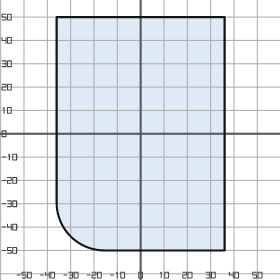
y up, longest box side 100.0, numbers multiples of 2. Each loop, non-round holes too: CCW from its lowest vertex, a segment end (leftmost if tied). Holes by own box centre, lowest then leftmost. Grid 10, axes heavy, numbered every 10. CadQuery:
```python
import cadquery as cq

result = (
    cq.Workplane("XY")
    .moveTo(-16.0, -50.0)
    .lineTo(36.0, -50.0)
    .lineTo(36.0, 50.0)
    .lineTo(-36.0, 50.0)
    .lineTo(-36.0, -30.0)
    .threePointArc((-30.0, -44.0), (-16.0, -50.0))
    .close()
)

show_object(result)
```